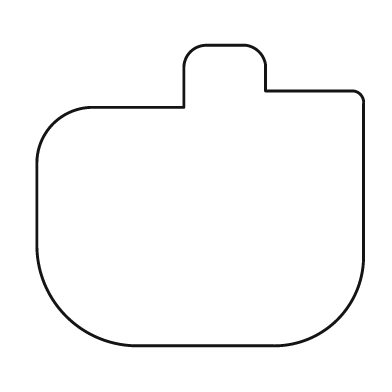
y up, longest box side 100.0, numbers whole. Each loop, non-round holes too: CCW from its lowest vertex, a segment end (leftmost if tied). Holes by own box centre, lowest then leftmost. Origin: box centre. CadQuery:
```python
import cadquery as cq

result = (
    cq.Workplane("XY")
    .moveTo(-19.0, -46.0)
    .lineTo(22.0, -46.0)
    .threePointArc((42.0, -38.0), (50.0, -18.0))
    .lineTo(50.0, 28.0)
    .threePointArc((49.0, 31.0), (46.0, 32.0))
    .lineTo(20.0, 32.0)
    .lineTo(20.0, 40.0)
    .threePointArc((18.0, 44.0), (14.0, 46.0))
    .lineTo(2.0, 46.0)
    .threePointArc((-3.0, 44.0), (-5.0, 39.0))
    .lineTo(-5.0, 27.0)
    .lineTo(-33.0, 27.0)
    .threePointArc((-45.0, 22.0), (-50.0, 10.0))
    .lineTo(-50.0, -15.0)
    .threePointArc((-41.0, -37.0), (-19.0, -46.0))
    .close()
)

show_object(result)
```